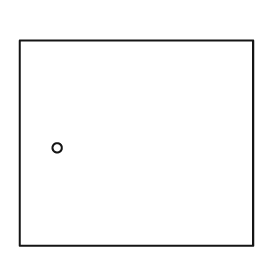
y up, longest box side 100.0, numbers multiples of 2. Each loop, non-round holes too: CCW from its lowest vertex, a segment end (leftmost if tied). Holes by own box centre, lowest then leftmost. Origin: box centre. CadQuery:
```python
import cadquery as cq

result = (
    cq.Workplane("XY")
    .moveTo(-50.0, -44.0)
    .lineTo(50.0, -44.0)
    .lineTo(50.0, 44.0)
    .lineTo(-50.0, 44.0)
    .close()
    .moveTo(-34.0, -2.0)
    .circle(2.0)
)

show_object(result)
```